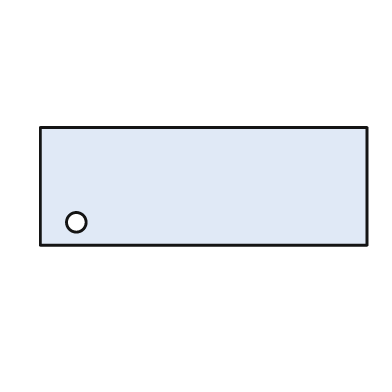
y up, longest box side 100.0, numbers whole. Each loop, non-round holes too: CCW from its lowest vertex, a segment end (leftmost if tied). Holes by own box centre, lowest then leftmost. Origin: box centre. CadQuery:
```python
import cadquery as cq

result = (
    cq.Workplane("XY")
    .moveTo(-50.0, -18.0)
    .lineTo(50.0, -18.0)
    .lineTo(50.0, 18.0)
    .lineTo(-50.0, 18.0)
    .close()
    .moveTo(-39.0, -11.0)
    .circle(3.0)
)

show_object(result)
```